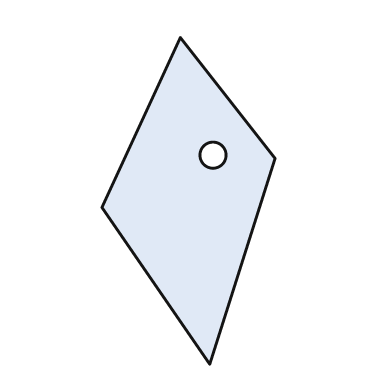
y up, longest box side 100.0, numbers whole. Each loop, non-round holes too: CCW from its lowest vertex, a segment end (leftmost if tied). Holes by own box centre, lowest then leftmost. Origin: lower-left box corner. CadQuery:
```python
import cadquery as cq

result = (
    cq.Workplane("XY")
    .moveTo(33.0, 0.0)
    .lineTo(53.0, 63.0)
    .lineTo(24.0, 100.0)
    .lineTo(0.0, 48.0)
    .close()
    .moveTo(34.0, 64.0)
    .circle(4.0)
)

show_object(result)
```